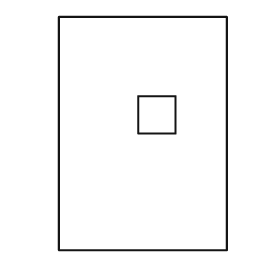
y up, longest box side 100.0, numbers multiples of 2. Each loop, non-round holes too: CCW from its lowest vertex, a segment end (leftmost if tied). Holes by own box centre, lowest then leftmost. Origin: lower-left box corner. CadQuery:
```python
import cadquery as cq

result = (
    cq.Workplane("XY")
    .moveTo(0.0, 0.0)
    .lineTo(72.0, 0.0)
    .lineTo(72.0, 100.0)
    .lineTo(0.0, 100.0)
    .close()
    .moveTo(34.0, 50.0)
    .lineTo(50.0, 50.0)
    .lineTo(50.0, 66.0)
    .lineTo(34.0, 66.0)
    .close()
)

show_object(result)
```